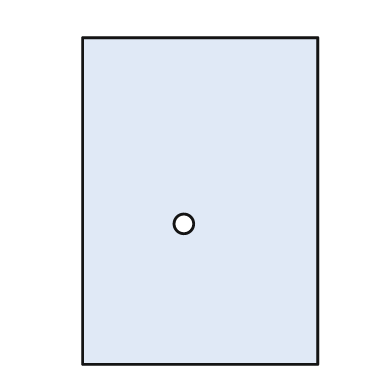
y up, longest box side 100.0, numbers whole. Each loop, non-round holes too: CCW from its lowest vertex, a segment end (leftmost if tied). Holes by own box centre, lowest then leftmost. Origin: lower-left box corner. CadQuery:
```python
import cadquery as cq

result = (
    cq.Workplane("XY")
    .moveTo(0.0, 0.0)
    .lineTo(72.0, 0.0)
    .lineTo(72.0, 100.0)
    .lineTo(0.0, 100.0)
    .close()
    .moveTo(31.0, 43.0)
    .circle(3.0)
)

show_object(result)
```